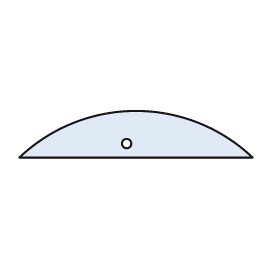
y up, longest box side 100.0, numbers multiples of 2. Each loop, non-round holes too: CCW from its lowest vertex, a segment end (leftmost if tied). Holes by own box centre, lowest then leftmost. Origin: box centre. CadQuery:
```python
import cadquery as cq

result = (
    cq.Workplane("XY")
    .moveTo(-50.0, -10.0)
    .lineTo(50.0, -10.0)
    .threePointArc((0.0, 10.0), (-50.0, -10.0))
    .close()
    .moveTo(-4.0, -4.0)
    .circle(2.0)
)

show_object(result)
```